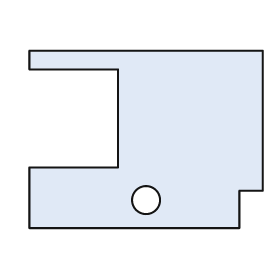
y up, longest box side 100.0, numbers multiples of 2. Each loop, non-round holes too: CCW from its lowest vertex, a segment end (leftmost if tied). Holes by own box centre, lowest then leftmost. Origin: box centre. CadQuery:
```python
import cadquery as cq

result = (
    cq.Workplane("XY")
    .moveTo(-50.0, -38.0)
    .lineTo(40.0, -38.0)
    .lineTo(40.0, -22.0)
    .lineTo(50.0, -22.0)
    .lineTo(50.0, 38.0)
    .lineTo(-50.0, 38.0)
    .lineTo(-50.0, 30.0)
    .lineTo(-12.0, 30.0)
    .lineTo(-12.0, -12.0)
    .lineTo(-50.0, -12.0)
    .close()
    .moveTo(0.0, -26.0)
    .circle(6.0)
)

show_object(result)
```